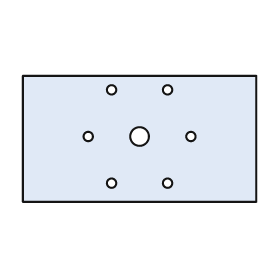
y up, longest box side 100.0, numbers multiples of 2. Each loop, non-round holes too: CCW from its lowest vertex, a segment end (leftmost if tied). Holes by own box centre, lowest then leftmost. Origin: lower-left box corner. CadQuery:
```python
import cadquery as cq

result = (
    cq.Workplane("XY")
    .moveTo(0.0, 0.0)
    .lineTo(100.0, 0.0)
    .lineTo(100.0, 54.0)
    .lineTo(0.0, 54.0)
    .close()
    .moveTo(38.0, 8.0)
    .circle(2.0)
    .moveTo(62.0, 8.0)
    .circle(2.0)
    .moveTo(28.0, 28.0)
    .circle(2.0)
    .moveTo(50.0, 28.0)
    .circle(4.0)
    .moveTo(72.0, 28.0)
    .circle(2.0)
    .moveTo(38.0, 48.0)
    .circle(2.0)
    .moveTo(62.0, 48.0)
    .circle(2.0)
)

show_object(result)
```